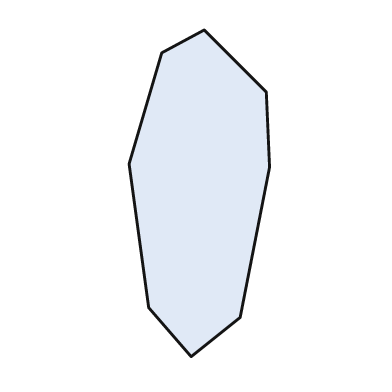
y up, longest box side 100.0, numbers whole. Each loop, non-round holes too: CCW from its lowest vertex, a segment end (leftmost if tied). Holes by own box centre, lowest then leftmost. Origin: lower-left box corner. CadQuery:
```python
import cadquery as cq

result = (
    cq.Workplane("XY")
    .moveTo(19.0, 0.0)
    .lineTo(34.0, 12.0)
    .lineTo(43.0, 58.0)
    .lineTo(42.0, 81.0)
    .lineTo(23.0, 100.0)
    .lineTo(10.0, 93.0)
    .lineTo(0.0, 59.0)
    .lineTo(6.0, 15.0)
    .close()
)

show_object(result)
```